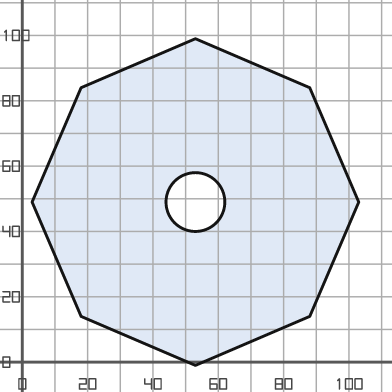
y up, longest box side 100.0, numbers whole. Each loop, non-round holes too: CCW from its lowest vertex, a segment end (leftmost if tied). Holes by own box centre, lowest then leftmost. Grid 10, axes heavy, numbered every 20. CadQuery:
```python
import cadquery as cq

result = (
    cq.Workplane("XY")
    .moveTo(53.0, -1.0)
    .lineTo(88.0, 14.0)
    .lineTo(103.0, 49.0)
    .lineTo(88.0, 84.0)
    .lineTo(53.0, 99.0)
    .lineTo(18.0, 84.0)
    .lineTo(3.0, 49.0)
    .lineTo(18.0, 14.0)
    .close()
    .moveTo(53.0, 49.0)
    .circle(9.0)
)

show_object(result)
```